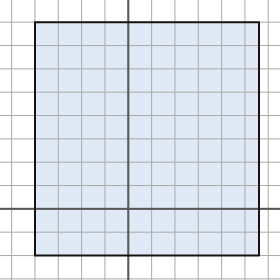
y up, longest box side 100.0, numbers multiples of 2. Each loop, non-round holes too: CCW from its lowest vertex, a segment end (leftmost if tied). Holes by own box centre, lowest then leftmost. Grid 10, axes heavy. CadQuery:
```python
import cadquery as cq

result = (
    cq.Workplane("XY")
    .moveTo(-40.0, -20.0)
    .lineTo(56.0, -20.0)
    .lineTo(56.0, 80.0)
    .lineTo(-40.0, 80.0)
    .close()
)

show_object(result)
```